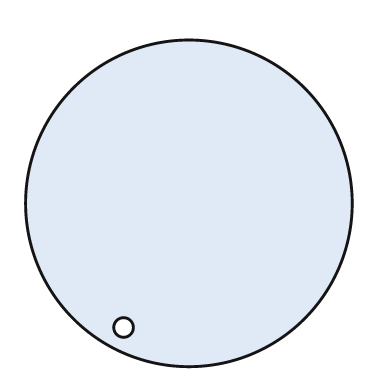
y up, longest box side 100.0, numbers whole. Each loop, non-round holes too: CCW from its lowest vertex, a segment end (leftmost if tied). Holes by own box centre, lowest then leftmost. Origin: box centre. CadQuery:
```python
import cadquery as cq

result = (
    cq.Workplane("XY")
    .moveTo(0.0, 0.0)
    .circle(50.0)
    .moveTo(-20.0, -38.0)
    .circle(3.0)
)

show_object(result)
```